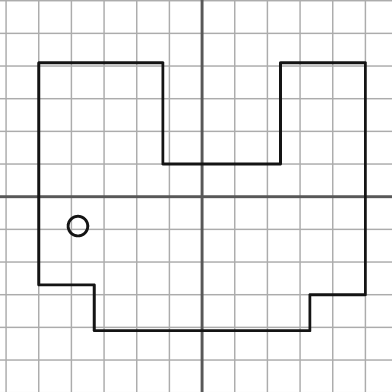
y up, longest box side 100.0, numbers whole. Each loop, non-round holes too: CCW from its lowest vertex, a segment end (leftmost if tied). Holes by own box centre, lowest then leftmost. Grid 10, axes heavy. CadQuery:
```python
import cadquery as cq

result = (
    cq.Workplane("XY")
    .moveTo(-33.0, -41.0)
    .lineTo(33.0, -41.0)
    .lineTo(33.0, -30.0)
    .lineTo(50.0, -30.0)
    .lineTo(50.0, 41.0)
    .lineTo(24.0, 41.0)
    .lineTo(24.0, 10.0)
    .lineTo(-12.0, 10.0)
    .lineTo(-12.0, 41.0)
    .lineTo(-50.0, 41.0)
    .lineTo(-50.0, -27.0)
    .lineTo(-33.0, -27.0)
    .close()
    .moveTo(-38.0, -9.0)
    .circle(3.0)
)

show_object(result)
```